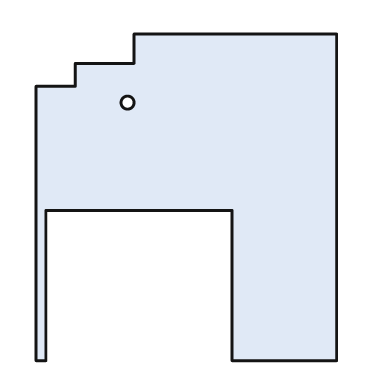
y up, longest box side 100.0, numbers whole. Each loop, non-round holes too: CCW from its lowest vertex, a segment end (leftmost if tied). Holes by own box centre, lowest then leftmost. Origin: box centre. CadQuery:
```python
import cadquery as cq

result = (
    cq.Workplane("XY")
    .moveTo(-46.0, -50.0)
    .lineTo(-43.0, -50.0)
    .lineTo(-43.0, -4.0)
    .lineTo(14.0, -4.0)
    .lineTo(14.0, -50.0)
    .lineTo(46.0, -50.0)
    .lineTo(46.0, 50.0)
    .lineTo(-16.0, 50.0)
    .lineTo(-16.0, 41.0)
    .lineTo(-34.0, 41.0)
    .lineTo(-34.0, 34.0)
    .lineTo(-46.0, 34.0)
    .close()
    .moveTo(-18.0, 29.0)
    .circle(2.0)
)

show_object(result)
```